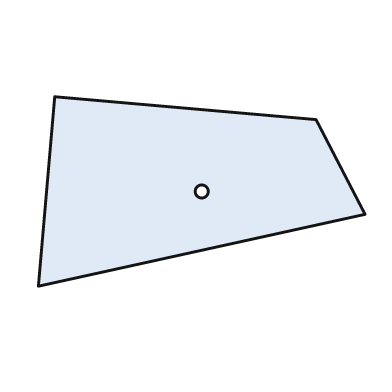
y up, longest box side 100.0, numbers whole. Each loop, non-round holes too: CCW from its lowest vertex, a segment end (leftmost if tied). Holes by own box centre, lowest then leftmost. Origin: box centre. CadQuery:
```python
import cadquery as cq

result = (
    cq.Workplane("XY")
    .moveTo(-50.0, -29.0)
    .lineTo(50.0, -7.0)
    .lineTo(35.0, 22.0)
    .lineTo(-45.0, 29.0)
    .close()
    .moveTo(0.0, 0.0)
    .circle(2.0)
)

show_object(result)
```